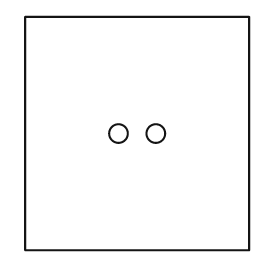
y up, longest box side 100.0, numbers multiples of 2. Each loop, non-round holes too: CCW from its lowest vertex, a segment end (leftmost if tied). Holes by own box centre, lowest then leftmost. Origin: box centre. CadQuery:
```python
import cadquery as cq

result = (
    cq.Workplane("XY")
    .moveTo(-48.0, -50.0)
    .lineTo(48.0, -50.0)
    .lineTo(48.0, 50.0)
    .lineTo(-48.0, 50.0)
    .close()
    .moveTo(-8.0, 0.0)
    .circle(4.0)
    .moveTo(8.0, 0.0)
    .circle(4.0)
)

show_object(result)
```